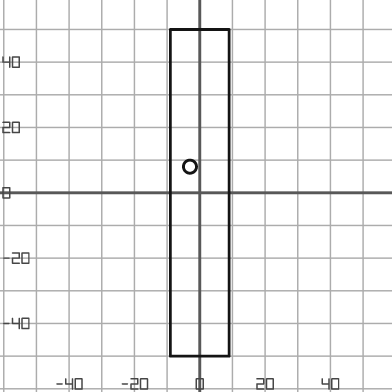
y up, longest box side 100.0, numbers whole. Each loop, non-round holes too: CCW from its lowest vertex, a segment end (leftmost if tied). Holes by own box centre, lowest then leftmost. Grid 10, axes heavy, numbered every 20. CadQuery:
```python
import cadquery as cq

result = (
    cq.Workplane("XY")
    .moveTo(-9.0, -50.0)
    .lineTo(9.0, -50.0)
    .lineTo(9.0, 50.0)
    .lineTo(-9.0, 50.0)
    .close()
    .moveTo(-3.0, 8.0)
    .circle(2.0)
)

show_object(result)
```